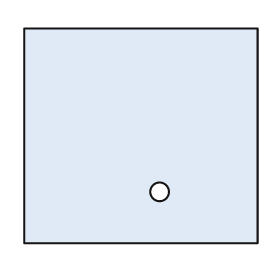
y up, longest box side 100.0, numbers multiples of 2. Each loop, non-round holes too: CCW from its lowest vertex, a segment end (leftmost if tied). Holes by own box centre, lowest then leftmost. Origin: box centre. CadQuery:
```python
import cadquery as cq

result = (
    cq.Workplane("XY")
    .moveTo(-50.0, -46.0)
    .lineTo(50.0, -46.0)
    .lineTo(50.0, 46.0)
    .lineTo(-50.0, 46.0)
    .close()
    .moveTo(8.0, -24.0)
    .circle(4.0)
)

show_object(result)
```